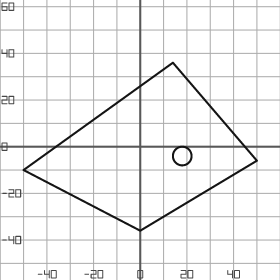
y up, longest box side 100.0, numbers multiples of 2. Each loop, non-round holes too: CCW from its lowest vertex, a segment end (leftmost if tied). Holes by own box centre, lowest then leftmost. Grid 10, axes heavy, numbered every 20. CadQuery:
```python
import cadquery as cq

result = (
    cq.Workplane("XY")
    .moveTo(0.0, -36.0)
    .lineTo(50.0, -6.0)
    .lineTo(14.0, 36.0)
    .lineTo(-50.0, -10.0)
    .close()
    .moveTo(18.0, -4.0)
    .circle(4.0)
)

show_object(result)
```